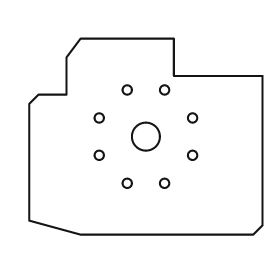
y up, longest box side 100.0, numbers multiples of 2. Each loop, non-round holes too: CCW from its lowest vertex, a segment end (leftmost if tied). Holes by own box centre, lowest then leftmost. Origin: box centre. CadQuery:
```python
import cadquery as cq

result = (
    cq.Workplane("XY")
    .moveTo(-28.0, -42.0)
    .lineTo(46.0, -42.0)
    .lineTo(50.0, -38.0)
    .lineTo(50.0, 26.0)
    .lineTo(12.0, 26.0)
    .lineTo(12.0, 42.0)
    .lineTo(-28.0, 42.0)
    .lineTo(-34.0, 34.0)
    .lineTo(-34.0, 18.0)
    .lineTo(-46.0, 18.0)
    .lineTo(-50.0, 14.0)
    .lineTo(-50.0, -36.0)
    .close()
    .moveTo(-8.0, -20.0)
    .circle(2.0)
    .moveTo(8.0, -20.0)
    .circle(2.0)
    .moveTo(-20.0, -8.0)
    .circle(2.0)
    .moveTo(20.0, -8.0)
    .circle(2.0)
    .moveTo(0.0, 0.0)
    .circle(6.0)
    .moveTo(-20.0, 8.0)
    .circle(2.0)
    .moveTo(20.0, 8.0)
    .circle(2.0)
    .moveTo(-8.0, 20.0)
    .circle(2.0)
    .moveTo(8.0, 20.0)
    .circle(2.0)
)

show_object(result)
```